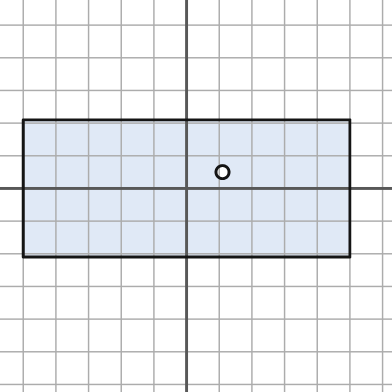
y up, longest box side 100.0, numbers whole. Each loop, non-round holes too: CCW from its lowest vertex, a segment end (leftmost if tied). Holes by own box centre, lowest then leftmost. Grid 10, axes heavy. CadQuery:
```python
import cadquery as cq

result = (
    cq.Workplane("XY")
    .moveTo(-50.0, -21.0)
    .lineTo(50.0, -21.0)
    .lineTo(50.0, 21.0)
    .lineTo(-50.0, 21.0)
    .close()
    .moveTo(11.0, 5.0)
    .circle(2.0)
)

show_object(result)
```